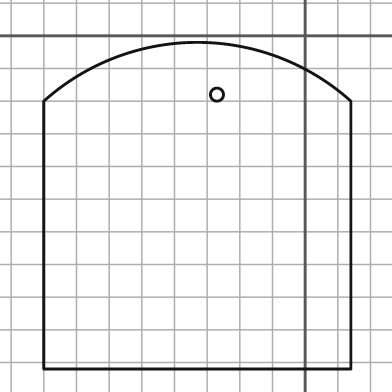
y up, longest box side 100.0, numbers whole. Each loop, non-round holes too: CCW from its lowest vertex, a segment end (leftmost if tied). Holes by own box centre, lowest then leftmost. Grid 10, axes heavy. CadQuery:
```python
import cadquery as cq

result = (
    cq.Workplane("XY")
    .moveTo(-80.0, -102.0)
    .lineTo(14.0, -102.0)
    .lineTo(14.0, -20.0)
    .threePointArc((-33.0, -2.0), (-80.0, -20.0))
    .close()
    .moveTo(-27.0, -18.0)
    .circle(2.0)
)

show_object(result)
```